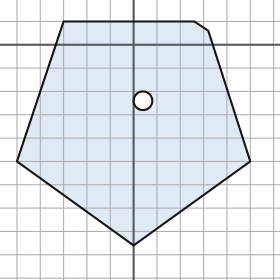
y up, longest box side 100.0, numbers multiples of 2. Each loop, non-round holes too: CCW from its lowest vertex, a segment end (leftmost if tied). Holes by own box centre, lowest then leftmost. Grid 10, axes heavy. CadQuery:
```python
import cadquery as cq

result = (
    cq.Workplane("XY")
    .moveTo(0.0, -86.0)
    .lineTo(50.0, -50.0)
    .lineTo(32.0, 6.0)
    .lineTo(26.0, 10.0)
    .lineTo(-30.0, 10.0)
    .lineTo(-50.0, -50.0)
    .close()
    .moveTo(4.0, -24.0)
    .circle(4.0)
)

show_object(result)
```